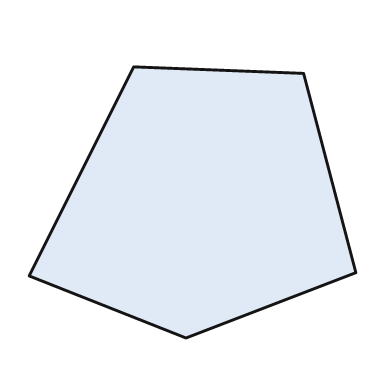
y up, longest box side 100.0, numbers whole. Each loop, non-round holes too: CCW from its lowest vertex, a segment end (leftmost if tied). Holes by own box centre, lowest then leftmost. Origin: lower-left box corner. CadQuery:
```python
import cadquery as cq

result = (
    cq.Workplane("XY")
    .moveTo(48.0, 0.0)
    .lineTo(100.0, 20.0)
    .lineTo(84.0, 81.0)
    .lineTo(32.0, 83.0)
    .lineTo(0.0, 19.0)
    .close()
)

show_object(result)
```